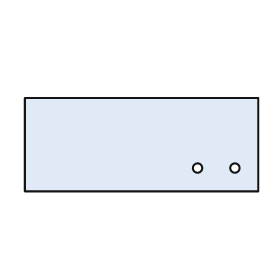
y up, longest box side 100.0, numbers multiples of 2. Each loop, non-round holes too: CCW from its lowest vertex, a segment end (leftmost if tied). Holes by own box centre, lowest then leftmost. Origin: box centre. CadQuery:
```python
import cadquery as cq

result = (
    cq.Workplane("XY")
    .moveTo(-50.0, -20.0)
    .lineTo(50.0, -20.0)
    .lineTo(50.0, 20.0)
    .lineTo(-50.0, 20.0)
    .close()
    .moveTo(24.0, -10.0)
    .circle(2.0)
    .moveTo(40.0, -10.0)
    .circle(2.0)
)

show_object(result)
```